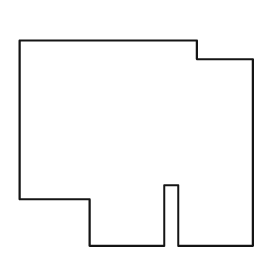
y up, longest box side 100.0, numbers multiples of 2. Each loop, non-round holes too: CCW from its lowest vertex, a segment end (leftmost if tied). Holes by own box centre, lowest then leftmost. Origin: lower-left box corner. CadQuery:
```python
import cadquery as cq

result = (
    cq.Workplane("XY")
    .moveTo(30.0, 0.0)
    .lineTo(62.0, 0.0)
    .lineTo(62.0, 26.0)
    .lineTo(68.0, 26.0)
    .lineTo(68.0, 0.0)
    .lineTo(100.0, 0.0)
    .lineTo(100.0, 80.0)
    .lineTo(76.0, 80.0)
    .lineTo(76.0, 88.0)
    .lineTo(0.0, 88.0)
    .lineTo(0.0, 20.0)
    .lineTo(30.0, 20.0)
    .close()
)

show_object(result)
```